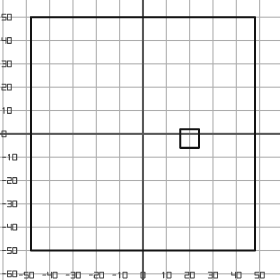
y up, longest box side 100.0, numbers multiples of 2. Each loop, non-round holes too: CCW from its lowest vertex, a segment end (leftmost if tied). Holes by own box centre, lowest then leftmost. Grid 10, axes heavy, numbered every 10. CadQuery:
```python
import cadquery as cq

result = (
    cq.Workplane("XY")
    .moveTo(-48.0, -50.0)
    .lineTo(48.0, -50.0)
    .lineTo(48.0, 50.0)
    .lineTo(-48.0, 50.0)
    .close()
    .moveTo(16.0, -6.0)
    .lineTo(24.0, -6.0)
    .lineTo(24.0, 2.0)
    .lineTo(16.0, 2.0)
    .close()
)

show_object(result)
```